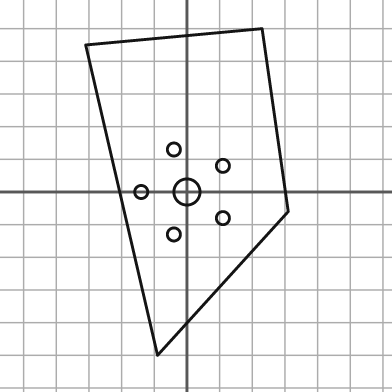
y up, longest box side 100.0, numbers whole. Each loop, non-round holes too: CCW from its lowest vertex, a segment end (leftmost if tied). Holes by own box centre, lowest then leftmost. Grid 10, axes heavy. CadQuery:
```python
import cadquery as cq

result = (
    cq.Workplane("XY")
    .moveTo(-9.0, -50.0)
    .lineTo(31.0, -6.0)
    .lineTo(23.0, 50.0)
    .lineTo(-31.0, 45.0)
    .close()
    .moveTo(-4.0, -13.0)
    .circle(2.0)
    .moveTo(11.0, -8.0)
    .circle(2.0)
    .moveTo(-14.0, 0.0)
    .circle(2.0)
    .moveTo(0.0, 0.0)
    .circle(4.0)
    .moveTo(11.0, 8.0)
    .circle(2.0)
    .moveTo(-4.0, 13.0)
    .circle(2.0)
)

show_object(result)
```